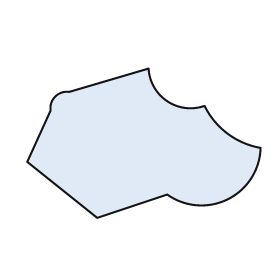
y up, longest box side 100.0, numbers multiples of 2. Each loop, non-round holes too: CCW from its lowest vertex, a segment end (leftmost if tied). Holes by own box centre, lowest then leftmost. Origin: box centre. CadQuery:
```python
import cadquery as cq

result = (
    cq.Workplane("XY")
    .moveTo(-20.0, -32.0)
    .lineTo(10.0, -22.0)
    .threePointArc((36.0, -24.0), (50.0, -2.0))
    .threePointArc((36.0, 4.0), (26.0, 16.0))
    .threePointArc((10.0, 18.0), (2.0, 32.0))
    .lineTo(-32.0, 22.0)
    .threePointArc((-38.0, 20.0), (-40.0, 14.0))
    .lineTo(-50.0, -8.0)
    .close()
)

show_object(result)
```